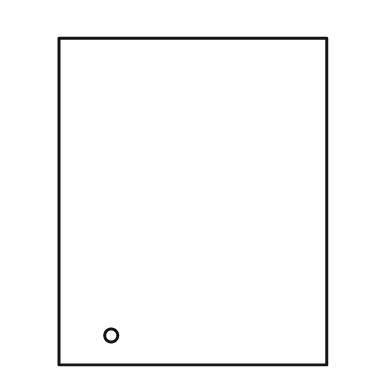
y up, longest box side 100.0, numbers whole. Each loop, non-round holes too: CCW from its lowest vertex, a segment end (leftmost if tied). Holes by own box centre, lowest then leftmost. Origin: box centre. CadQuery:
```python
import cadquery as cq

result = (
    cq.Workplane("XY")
    .moveTo(-41.0, -50.0)
    .lineTo(41.0, -50.0)
    .lineTo(41.0, 50.0)
    .lineTo(-41.0, 50.0)
    .close()
    .moveTo(-25.0, -41.0)
    .circle(2.0)
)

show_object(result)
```